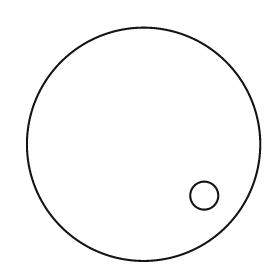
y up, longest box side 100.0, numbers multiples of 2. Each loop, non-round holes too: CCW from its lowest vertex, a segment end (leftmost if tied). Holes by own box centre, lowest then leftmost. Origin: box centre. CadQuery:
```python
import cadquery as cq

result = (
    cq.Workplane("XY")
    .moveTo(0.0, 0.0)
    .circle(50.0)
    .moveTo(26.0, -22.0)
    .circle(6.0)
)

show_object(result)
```